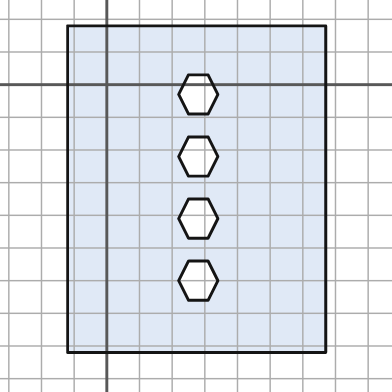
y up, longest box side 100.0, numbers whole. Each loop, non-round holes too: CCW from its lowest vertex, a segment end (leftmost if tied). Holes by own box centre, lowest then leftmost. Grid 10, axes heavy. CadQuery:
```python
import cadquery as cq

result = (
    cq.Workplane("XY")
    .moveTo(-12.0, -82.0)
    .lineTo(67.0, -82.0)
    .lineTo(67.0, 18.0)
    .lineTo(-12.0, 18.0)
    .close()
    .moveTo(25.0, -66.0)
    .lineTo(31.0, -66.0)
    .lineTo(34.0, -60.0)
    .lineTo(31.0, -54.0)
    .lineTo(25.0, -54.0)
    .lineTo(22.0, -60.0)
    .close()
    .moveTo(25.0, -47.0)
    .lineTo(31.0, -47.0)
    .lineTo(34.0, -41.0)
    .lineTo(31.0, -35.0)
    .lineTo(25.0, -35.0)
    .lineTo(22.0, -41.0)
    .close()
    .moveTo(25.0, -28.0)
    .lineTo(31.0, -28.0)
    .lineTo(34.0, -22.0)
    .lineTo(31.0, -16.0)
    .lineTo(25.0, -16.0)
    .lineTo(22.0, -22.0)
    .close()
    .moveTo(25.0, -9.0)
    .lineTo(31.0, -9.0)
    .lineTo(34.0, -3.0)
    .lineTo(31.0, 3.0)
    .lineTo(25.0, 3.0)
    .lineTo(22.0, -3.0)
    .close()
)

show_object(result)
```